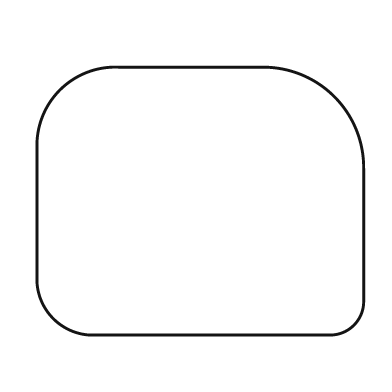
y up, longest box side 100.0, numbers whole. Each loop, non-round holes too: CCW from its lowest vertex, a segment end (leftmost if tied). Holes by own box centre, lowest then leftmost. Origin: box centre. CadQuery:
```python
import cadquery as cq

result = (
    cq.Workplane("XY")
    .moveTo(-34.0, -41.0)
    .lineTo(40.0, -41.0)
    .threePointArc((47.0, -38.0), (50.0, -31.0))
    .lineTo(50.0, 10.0)
    .threePointArc((41.0, 32.0), (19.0, 41.0))
    .lineTo(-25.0, 41.0)
    .threePointArc((-43.0, 34.0), (-50.0, 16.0))
    .lineTo(-50.0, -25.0)
    .threePointArc((-45.0, -36.0), (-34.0, -41.0))
    .close()
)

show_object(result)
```